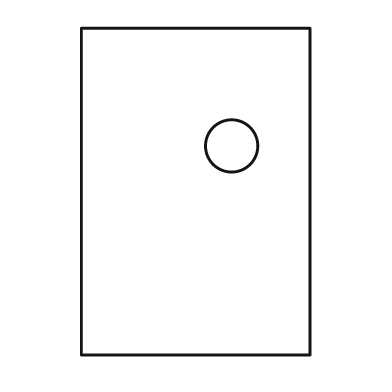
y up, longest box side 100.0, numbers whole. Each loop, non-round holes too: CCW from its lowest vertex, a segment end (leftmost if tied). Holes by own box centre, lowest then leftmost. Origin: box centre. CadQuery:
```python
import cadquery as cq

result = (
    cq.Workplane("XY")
    .moveTo(-35.0, -50.0)
    .lineTo(35.0, -50.0)
    .lineTo(35.0, 50.0)
    .lineTo(-35.0, 50.0)
    .close()
    .moveTo(11.0, 14.0)
    .circle(8.0)
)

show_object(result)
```